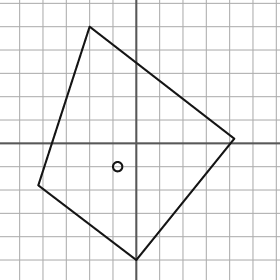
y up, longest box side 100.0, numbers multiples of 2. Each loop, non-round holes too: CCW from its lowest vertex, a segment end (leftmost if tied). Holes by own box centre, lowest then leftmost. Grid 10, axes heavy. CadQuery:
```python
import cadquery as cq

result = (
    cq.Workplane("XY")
    .moveTo(0.0, -50.0)
    .lineTo(42.0, 2.0)
    .lineTo(-20.0, 50.0)
    .lineTo(-42.0, -18.0)
    .close()
    .moveTo(-8.0, -10.0)
    .circle(2.0)
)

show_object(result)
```